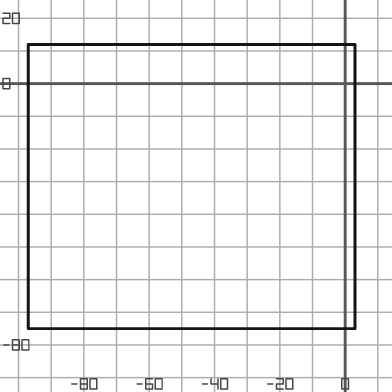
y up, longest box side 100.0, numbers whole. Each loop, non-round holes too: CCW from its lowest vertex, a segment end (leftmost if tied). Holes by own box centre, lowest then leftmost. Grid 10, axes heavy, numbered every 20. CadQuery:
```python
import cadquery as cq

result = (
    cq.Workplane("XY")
    .moveTo(-97.0, -75.0)
    .lineTo(3.0, -75.0)
    .lineTo(3.0, 12.0)
    .lineTo(-97.0, 12.0)
    .close()
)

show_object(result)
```